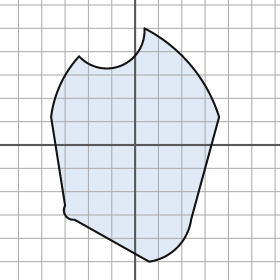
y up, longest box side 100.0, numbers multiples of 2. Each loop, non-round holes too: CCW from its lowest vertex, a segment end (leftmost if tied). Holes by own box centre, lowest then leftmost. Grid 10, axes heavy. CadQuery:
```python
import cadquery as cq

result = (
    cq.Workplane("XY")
    .moveTo(6.0, -50.0)
    .threePointArc((18.0, -44.0), (24.0, -32.0))
    .lineTo(36.0, 12.0)
    .threePointArc((24.0, 34.0), (4.0, 50.0))
    .threePointArc((-6.0, 34.0), (-24.0, 38.0))
    .threePointArc((-32.0, 26.0), (-36.0, 12.0))
    .lineTo(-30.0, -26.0)
    .threePointArc((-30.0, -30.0), (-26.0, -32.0))
    .close()
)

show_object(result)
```